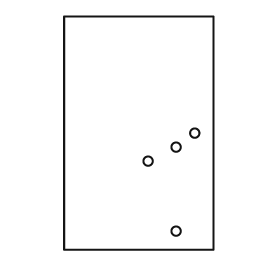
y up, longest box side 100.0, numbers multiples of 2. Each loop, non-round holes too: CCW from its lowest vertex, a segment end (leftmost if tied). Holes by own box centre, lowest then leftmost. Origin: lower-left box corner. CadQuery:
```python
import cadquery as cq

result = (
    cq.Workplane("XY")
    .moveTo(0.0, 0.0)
    .lineTo(64.0, 0.0)
    .lineTo(64.0, 100.0)
    .lineTo(0.0, 100.0)
    .close()
    .moveTo(48.0, 8.0)
    .circle(2.0)
    .moveTo(36.0, 38.0)
    .circle(2.0)
    .moveTo(48.0, 44.0)
    .circle(2.0)
    .moveTo(56.0, 50.0)
    .circle(2.0)
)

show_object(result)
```